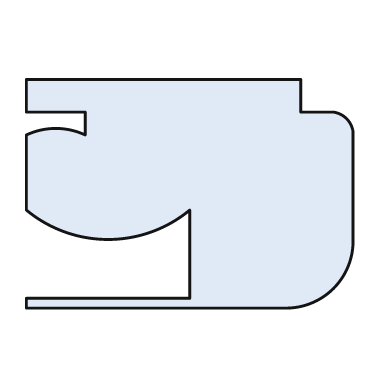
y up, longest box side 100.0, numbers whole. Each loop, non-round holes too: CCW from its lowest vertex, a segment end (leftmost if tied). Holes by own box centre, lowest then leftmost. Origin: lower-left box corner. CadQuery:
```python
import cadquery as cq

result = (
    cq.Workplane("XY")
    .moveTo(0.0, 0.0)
    .lineTo(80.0, 0.0)
    .threePointArc((94.0, 6.0), (100.0, 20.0))
    .lineTo(100.0, 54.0)
    .threePointArc((98.0, 58.0), (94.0, 60.0))
    .lineTo(84.0, 60.0)
    .lineTo(84.0, 70.0)
    .lineTo(0.0, 70.0)
    .lineTo(0.0, 60.0)
    .lineTo(18.0, 60.0)
    .lineTo(18.0, 53.0)
    .threePointArc((9.0, 55.0), (0.0, 53.0))
    .lineTo(0.0, 30.0)
    .threePointArc((25.0, 21.0), (50.0, 30.0))
    .lineTo(50.0, 3.0)
    .lineTo(0.0, 3.0)
    .close()
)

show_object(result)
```